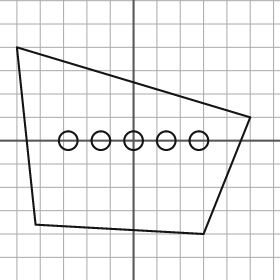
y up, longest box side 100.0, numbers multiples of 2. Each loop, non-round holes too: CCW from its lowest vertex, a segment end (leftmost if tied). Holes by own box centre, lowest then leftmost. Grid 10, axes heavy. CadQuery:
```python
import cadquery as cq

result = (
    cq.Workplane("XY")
    .moveTo(30.0, -40.0)
    .lineTo(50.0, 10.0)
    .lineTo(-50.0, 40.0)
    .lineTo(-42.0, -36.0)
    .close()
    .moveTo(-28.0, 0.0)
    .circle(4.0)
    .moveTo(-14.0, 0.0)
    .circle(4.0)
    .moveTo(0.0, 0.0)
    .circle(4.0)
    .moveTo(14.0, 0.0)
    .circle(4.0)
    .moveTo(28.0, 0.0)
    .circle(4.0)
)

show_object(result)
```